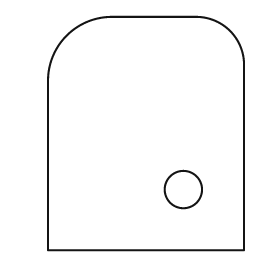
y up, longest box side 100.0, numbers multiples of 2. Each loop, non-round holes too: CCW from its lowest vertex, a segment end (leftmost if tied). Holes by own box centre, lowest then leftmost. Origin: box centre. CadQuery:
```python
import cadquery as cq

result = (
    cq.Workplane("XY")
    .moveTo(-42.0, -50.0)
    .lineTo(42.0, -50.0)
    .lineTo(42.0, 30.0)
    .threePointArc((36.0, 44.0), (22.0, 50.0))
    .lineTo(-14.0, 50.0)
    .threePointArc((-34.0, 42.0), (-42.0, 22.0))
    .close()
    .moveTo(16.0, -24.0)
    .circle(8.0)
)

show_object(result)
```